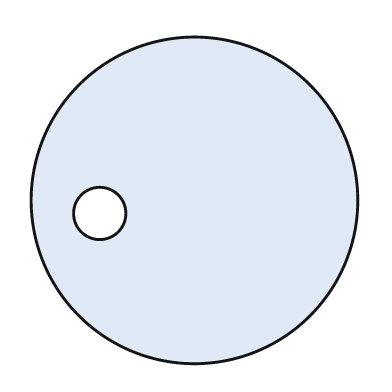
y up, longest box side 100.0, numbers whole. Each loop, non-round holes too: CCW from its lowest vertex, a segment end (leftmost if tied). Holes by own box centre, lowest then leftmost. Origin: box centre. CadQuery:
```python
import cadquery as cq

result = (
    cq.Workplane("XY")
    .moveTo(0.0, 0.0)
    .circle(50.0)
    .moveTo(-29.0, -4.0)
    .circle(8.0)
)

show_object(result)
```